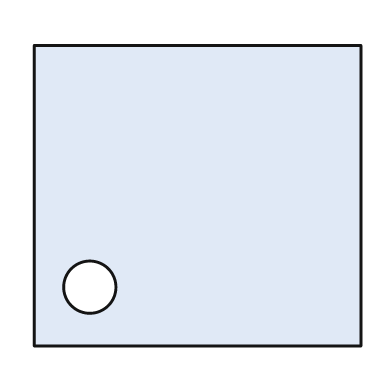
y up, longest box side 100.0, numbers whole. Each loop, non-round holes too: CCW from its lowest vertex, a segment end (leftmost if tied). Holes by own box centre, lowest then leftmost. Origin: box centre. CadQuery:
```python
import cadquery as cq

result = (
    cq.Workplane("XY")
    .moveTo(-50.0, -46.0)
    .lineTo(50.0, -46.0)
    .lineTo(50.0, 46.0)
    .lineTo(-50.0, 46.0)
    .close()
    .moveTo(-33.0, -28.0)
    .circle(8.0)
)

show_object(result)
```